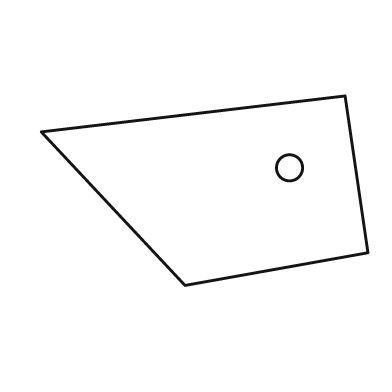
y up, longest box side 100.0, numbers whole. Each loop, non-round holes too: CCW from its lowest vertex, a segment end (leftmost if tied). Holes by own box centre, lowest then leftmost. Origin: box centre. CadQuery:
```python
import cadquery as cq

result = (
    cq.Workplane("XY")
    .moveTo(-6.0, -29.0)
    .lineTo(50.0, -19.0)
    .lineTo(43.0, 29.0)
    .lineTo(-50.0, 18.0)
    .close()
    .moveTo(26.0, 7.0)
    .circle(4.0)
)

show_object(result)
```